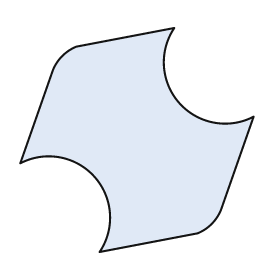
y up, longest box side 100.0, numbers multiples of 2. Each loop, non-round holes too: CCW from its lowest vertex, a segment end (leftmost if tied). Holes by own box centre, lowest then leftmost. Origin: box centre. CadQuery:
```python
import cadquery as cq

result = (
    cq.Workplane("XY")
    .moveTo(-16.0, -48.0)
    .lineTo(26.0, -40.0)
    .threePointArc((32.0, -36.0), (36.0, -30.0))
    .lineTo(50.0, 10.0)
    .threePointArc((18.0, 16.0), (16.0, 48.0))
    .lineTo(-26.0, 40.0)
    .threePointArc((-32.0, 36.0), (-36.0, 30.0))
    .lineTo(-50.0, -10.0)
    .threePointArc((-18.0, -16.0), (-16.0, -48.0))
    .close()
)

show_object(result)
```